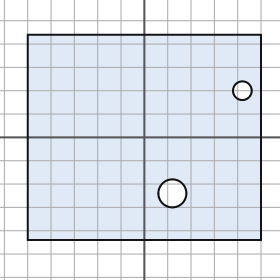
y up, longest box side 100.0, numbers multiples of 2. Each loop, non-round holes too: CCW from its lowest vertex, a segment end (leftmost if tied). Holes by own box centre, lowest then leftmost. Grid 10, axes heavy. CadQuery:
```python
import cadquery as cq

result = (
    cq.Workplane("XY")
    .moveTo(-50.0, -44.0)
    .lineTo(50.0, -44.0)
    .lineTo(50.0, 44.0)
    .lineTo(-50.0, 44.0)
    .close()
    .moveTo(12.0, -24.0)
    .circle(6.0)
    .moveTo(42.0, 20.0)
    .circle(4.0)
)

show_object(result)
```